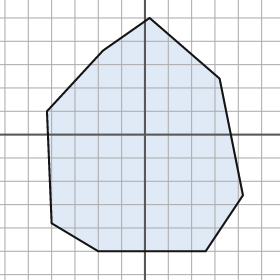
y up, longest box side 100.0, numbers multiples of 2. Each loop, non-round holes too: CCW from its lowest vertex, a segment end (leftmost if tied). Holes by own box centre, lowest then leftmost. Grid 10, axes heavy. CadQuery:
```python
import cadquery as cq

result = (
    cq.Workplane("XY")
    .moveTo(-20.0, -50.0)
    .lineTo(26.0, -50.0)
    .lineTo(42.0, -26.0)
    .lineTo(32.0, 24.0)
    .lineTo(2.0, 50.0)
    .lineTo(-18.0, 36.0)
    .lineTo(-42.0, 10.0)
    .lineTo(-40.0, -38.0)
    .close()
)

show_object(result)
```